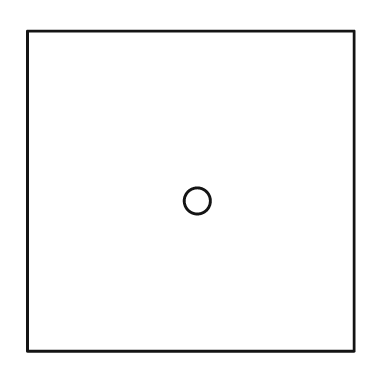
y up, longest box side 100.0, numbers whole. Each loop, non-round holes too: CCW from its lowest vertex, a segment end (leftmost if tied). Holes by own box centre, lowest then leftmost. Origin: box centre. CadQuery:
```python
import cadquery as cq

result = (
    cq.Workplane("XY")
    .moveTo(-50.0, -49.0)
    .lineTo(50.0, -49.0)
    .lineTo(50.0, 49.0)
    .lineTo(-50.0, 49.0)
    .close()
    .moveTo(2.0, -3.0)
    .circle(4.0)
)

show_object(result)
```